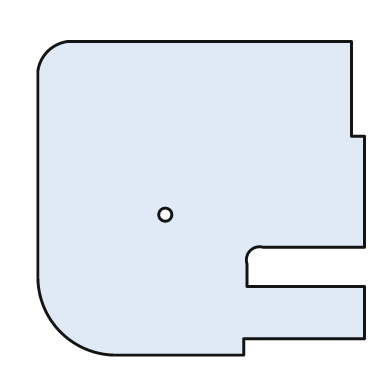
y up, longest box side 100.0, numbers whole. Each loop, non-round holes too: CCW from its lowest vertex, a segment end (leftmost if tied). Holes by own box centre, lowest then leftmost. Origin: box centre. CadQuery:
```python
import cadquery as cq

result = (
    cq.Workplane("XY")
    .moveTo(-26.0, -48.0)
    .lineTo(13.0, -48.0)
    .lineTo(13.0, -43.0)
    .lineTo(50.0, -43.0)
    .lineTo(50.0, -27.0)
    .lineTo(14.0, -27.0)
    .lineTo(14.0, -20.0)
    .threePointArc((15.0, -16.0), (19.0, -15.0))
    .lineTo(50.0, -15.0)
    .lineTo(50.0, 19.0)
    .lineTo(46.0, 19.0)
    .lineTo(46.0, 48.0)
    .lineTo(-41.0, 48.0)
    .threePointArc((-47.0, 45.0), (-50.0, 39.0))
    .lineTo(-50.0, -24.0)
    .threePointArc((-43.0, -41.0), (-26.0, -48.0))
    .close()
    .moveTo(-11.0, -5.0)
    .circle(2.0)
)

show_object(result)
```